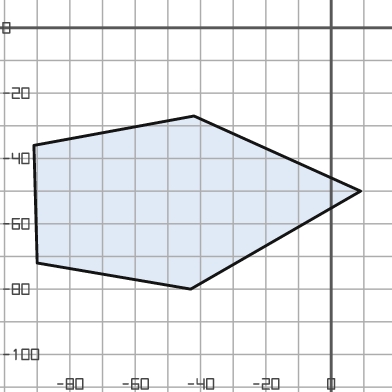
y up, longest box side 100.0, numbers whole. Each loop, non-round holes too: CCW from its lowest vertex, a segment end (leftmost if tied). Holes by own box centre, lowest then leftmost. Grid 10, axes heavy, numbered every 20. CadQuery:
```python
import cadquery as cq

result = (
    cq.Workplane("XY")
    .moveTo(-43.0, -80.0)
    .lineTo(9.0, -50.0)
    .lineTo(-42.0, -27.0)
    .lineTo(-91.0, -36.0)
    .lineTo(-90.0, -72.0)
    .close()
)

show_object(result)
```